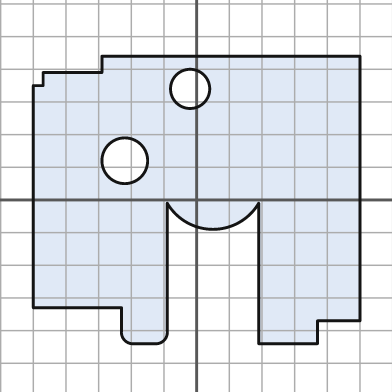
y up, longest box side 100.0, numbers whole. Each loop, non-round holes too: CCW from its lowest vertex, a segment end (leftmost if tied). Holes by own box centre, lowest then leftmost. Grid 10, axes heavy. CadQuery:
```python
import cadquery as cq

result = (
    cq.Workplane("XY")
    .moveTo(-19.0, -44.0)
    .lineTo(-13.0, -44.0)
    .threePointArc((-10.0, -43.0), (-9.0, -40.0))
    .lineTo(-9.0, -1.0)
    .threePointArc((5.0, -9.0), (19.0, -1.0))
    .lineTo(19.0, -44.0)
    .lineTo(37.0, -44.0)
    .lineTo(37.0, -37.0)
    .lineTo(50.0, -37.0)
    .lineTo(50.0, 44.0)
    .lineTo(-29.0, 44.0)
    .lineTo(-29.0, 39.0)
    .lineTo(-47.0, 39.0)
    .lineTo(-47.0, 35.0)
    .lineTo(-50.0, 35.0)
    .lineTo(-50.0, -33.0)
    .lineTo(-23.0, -33.0)
    .lineTo(-23.0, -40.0)
    .threePointArc((-22.0, -43.0), (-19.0, -44.0))
    .close()
    .moveTo(-22.0, 12.0)
    .circle(7.0)
    .moveTo(-2.0, 34.0)
    .circle(6.0)
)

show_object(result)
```